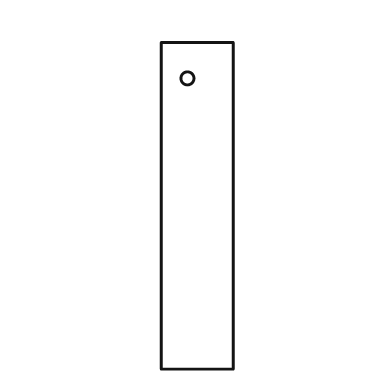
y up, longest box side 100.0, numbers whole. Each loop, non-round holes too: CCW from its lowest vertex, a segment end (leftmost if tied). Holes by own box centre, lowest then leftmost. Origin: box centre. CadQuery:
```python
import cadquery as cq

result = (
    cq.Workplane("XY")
    .moveTo(-11.0, -50.0)
    .lineTo(11.0, -50.0)
    .lineTo(11.0, 50.0)
    .lineTo(-11.0, 50.0)
    .close()
    .moveTo(-3.0, 39.0)
    .circle(2.0)
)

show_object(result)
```